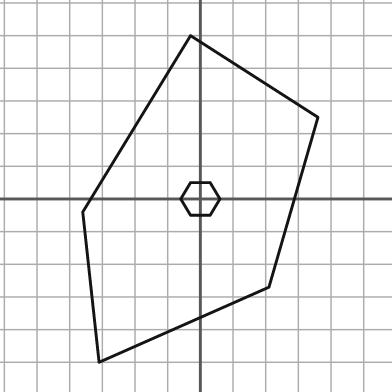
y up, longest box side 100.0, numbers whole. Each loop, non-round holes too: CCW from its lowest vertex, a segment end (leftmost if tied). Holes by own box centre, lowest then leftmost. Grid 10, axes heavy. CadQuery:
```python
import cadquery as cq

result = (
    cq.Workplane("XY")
    .moveTo(-31.0, -50.0)
    .lineTo(21.0, -27.0)
    .lineTo(36.0, 25.0)
    .lineTo(-3.0, 50.0)
    .lineTo(-36.0, -4.0)
    .close()
    .moveTo(-3.0, -5.0)
    .lineTo(3.0, -5.0)
    .lineTo(6.0, 0.0)
    .lineTo(3.0, 5.0)
    .lineTo(-3.0, 5.0)
    .lineTo(-6.0, 0.0)
    .close()
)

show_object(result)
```